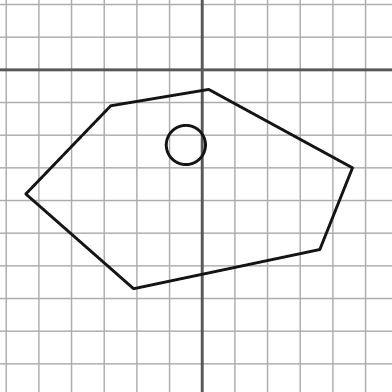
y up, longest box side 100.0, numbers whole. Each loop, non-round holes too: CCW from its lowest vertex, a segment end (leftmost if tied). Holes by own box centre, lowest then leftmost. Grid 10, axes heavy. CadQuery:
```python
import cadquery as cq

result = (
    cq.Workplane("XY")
    .moveTo(-21.0, -67.0)
    .lineTo(36.0, -55.0)
    .lineTo(46.0, -30.0)
    .lineTo(2.0, -6.0)
    .lineTo(-28.0, -11.0)
    .lineTo(-54.0, -38.0)
    .close()
    .moveTo(-5.0, -23.0)
    .circle(6.0)
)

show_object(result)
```